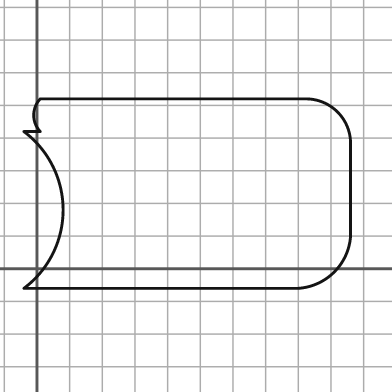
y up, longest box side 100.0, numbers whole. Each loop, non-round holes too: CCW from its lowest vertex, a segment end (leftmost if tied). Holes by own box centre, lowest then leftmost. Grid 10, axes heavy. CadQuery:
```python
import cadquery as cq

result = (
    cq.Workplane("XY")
    .moveTo(-4.0, -6.0)
    .lineTo(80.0, -6.0)
    .threePointArc((91.0, -1.0), (96.0, 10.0))
    .lineTo(96.0, 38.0)
    .threePointArc((92.0, 48.0), (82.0, 52.0))
    .lineTo(1.0, 52.0)
    .threePointArc((-1.0, 47.0), (1.0, 42.0))
    .lineTo(-4.0, 42.0)
    .threePointArc((8.0, 18.0), (-4.0, -6.0))
    .close()
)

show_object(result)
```